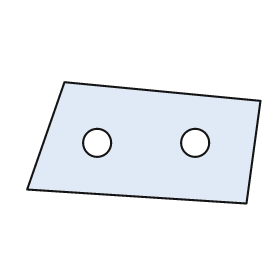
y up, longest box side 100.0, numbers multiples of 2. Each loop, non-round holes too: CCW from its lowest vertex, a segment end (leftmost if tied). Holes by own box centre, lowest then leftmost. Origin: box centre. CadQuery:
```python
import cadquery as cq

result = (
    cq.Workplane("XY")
    .moveTo(44.0, -26.0)
    .lineTo(50.0, 18.0)
    .lineTo(-34.0, 26.0)
    .lineTo(-50.0, -20.0)
    .close()
    .moveTo(-20.0, 0.0)
    .circle(6.0)
    .moveTo(22.0, 0.0)
    .circle(6.0)
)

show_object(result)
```